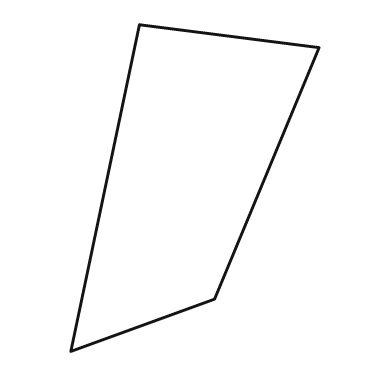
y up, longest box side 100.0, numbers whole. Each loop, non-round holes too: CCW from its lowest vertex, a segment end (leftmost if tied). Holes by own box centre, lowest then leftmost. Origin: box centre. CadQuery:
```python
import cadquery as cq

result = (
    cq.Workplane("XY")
    .moveTo(-38.0, -50.0)
    .lineTo(6.0, -34.0)
    .lineTo(38.0, 43.0)
    .lineTo(-17.0, 50.0)
    .close()
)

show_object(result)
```